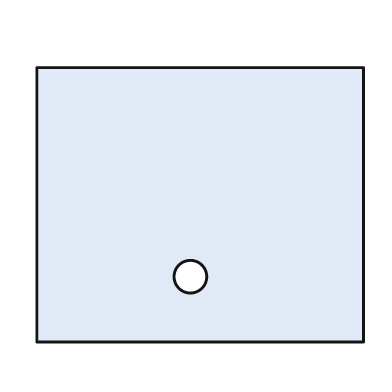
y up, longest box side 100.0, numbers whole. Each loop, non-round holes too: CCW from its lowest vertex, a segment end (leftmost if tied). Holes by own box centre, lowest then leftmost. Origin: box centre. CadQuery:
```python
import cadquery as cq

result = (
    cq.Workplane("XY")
    .moveTo(-50.0, -42.0)
    .lineTo(50.0, -42.0)
    .lineTo(50.0, 42.0)
    .lineTo(-50.0, 42.0)
    .close()
    .moveTo(-3.0, -22.0)
    .circle(5.0)
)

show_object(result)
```